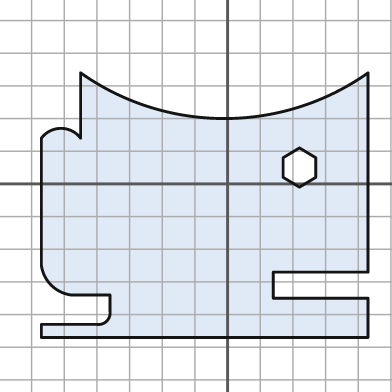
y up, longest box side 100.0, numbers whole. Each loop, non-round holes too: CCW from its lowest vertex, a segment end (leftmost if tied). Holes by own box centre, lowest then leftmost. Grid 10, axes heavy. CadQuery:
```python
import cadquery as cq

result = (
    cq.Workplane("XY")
    .moveTo(-57.0, -47.0)
    .lineTo(43.0, -47.0)
    .lineTo(43.0, -35.0)
    .lineTo(14.0, -35.0)
    .lineTo(14.0, -27.0)
    .lineTo(43.0, -27.0)
    .lineTo(43.0, 34.0)
    .threePointArc((-1.0, 20.0), (-45.0, 34.0))
    .lineTo(-45.0, 14.0)
    .threePointArc((-51.0, 17.0), (-57.0, 14.0))
    .lineTo(-57.0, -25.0)
    .threePointArc((-54.0, -31.0), (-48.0, -34.0))
    .lineTo(-36.0, -34.0)
    .lineTo(-36.0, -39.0)
    .threePointArc((-37.0, -42.0), (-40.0, -43.0))
    .lineTo(-57.0, -43.0)
    .close()
    .moveTo(22.0, -1.0)
    .lineTo(27.0, 2.0)
    .lineTo(27.0, 8.0)
    .lineTo(22.0, 11.0)
    .lineTo(17.0, 8.0)
    .lineTo(17.0, 2.0)
    .close()
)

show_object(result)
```